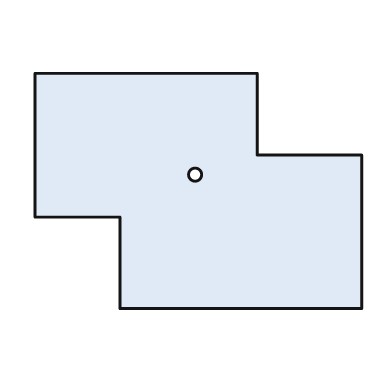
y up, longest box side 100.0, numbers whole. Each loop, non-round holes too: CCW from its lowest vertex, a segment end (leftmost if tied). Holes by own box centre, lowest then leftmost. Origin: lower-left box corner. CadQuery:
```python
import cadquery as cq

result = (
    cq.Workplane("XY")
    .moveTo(26.0, 0.0)
    .lineTo(100.0, 0.0)
    .lineTo(100.0, 47.0)
    .lineTo(68.0, 47.0)
    .lineTo(68.0, 72.0)
    .lineTo(0.0, 72.0)
    .lineTo(0.0, 28.0)
    .lineTo(26.0, 28.0)
    .close()
    .moveTo(49.0, 41.0)
    .circle(2.0)
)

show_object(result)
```